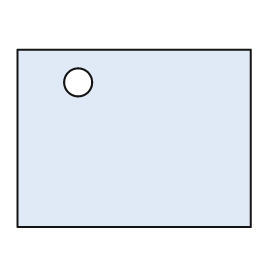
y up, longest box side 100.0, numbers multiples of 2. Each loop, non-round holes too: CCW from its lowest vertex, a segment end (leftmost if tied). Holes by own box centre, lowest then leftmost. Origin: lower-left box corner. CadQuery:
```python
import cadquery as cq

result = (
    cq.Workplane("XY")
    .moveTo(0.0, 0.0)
    .lineTo(100.0, 0.0)
    .lineTo(100.0, 76.0)
    .lineTo(0.0, 76.0)
    .close()
    .moveTo(26.0, 62.0)
    .circle(6.0)
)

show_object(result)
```